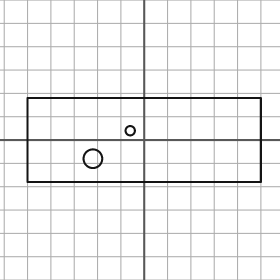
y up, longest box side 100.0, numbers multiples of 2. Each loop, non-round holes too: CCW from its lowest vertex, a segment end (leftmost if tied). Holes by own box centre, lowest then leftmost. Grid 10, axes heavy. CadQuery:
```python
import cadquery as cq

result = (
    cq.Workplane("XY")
    .moveTo(-50.0, -18.0)
    .lineTo(50.0, -18.0)
    .lineTo(50.0, 18.0)
    .lineTo(-50.0, 18.0)
    .close()
    .moveTo(-22.0, -8.0)
    .circle(4.0)
    .moveTo(-6.0, 4.0)
    .circle(2.0)
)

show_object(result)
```